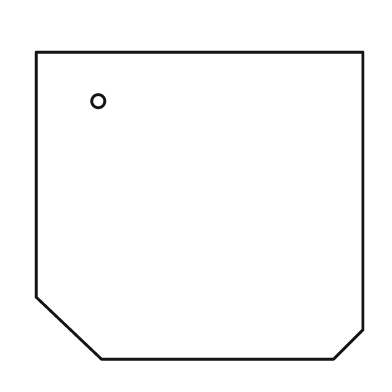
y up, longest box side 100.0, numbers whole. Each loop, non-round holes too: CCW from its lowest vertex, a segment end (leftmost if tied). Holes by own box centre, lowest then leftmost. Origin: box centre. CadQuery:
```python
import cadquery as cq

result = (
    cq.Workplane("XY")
    .moveTo(-30.0, -47.0)
    .lineTo(41.0, -47.0)
    .lineTo(50.0, -38.0)
    .lineTo(50.0, 47.0)
    .lineTo(-50.0, 47.0)
    .lineTo(-50.0, -28.0)
    .close()
    .moveTo(-31.0, 32.0)
    .circle(2.0)
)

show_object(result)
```